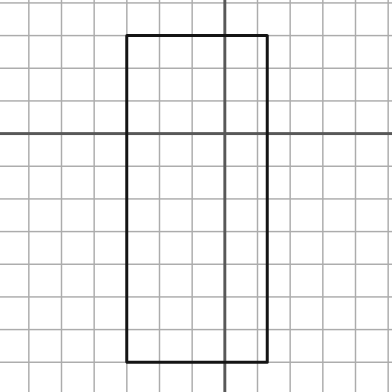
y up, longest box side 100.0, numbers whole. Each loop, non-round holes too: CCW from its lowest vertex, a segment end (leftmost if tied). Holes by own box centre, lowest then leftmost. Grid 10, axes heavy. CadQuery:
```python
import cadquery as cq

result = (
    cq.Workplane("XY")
    .moveTo(-30.0, -70.0)
    .lineTo(13.0, -70.0)
    .lineTo(13.0, 30.0)
    .lineTo(-30.0, 30.0)
    .close()
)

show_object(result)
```